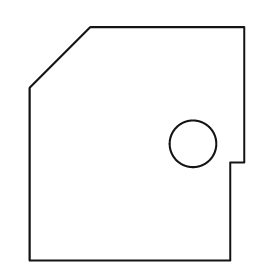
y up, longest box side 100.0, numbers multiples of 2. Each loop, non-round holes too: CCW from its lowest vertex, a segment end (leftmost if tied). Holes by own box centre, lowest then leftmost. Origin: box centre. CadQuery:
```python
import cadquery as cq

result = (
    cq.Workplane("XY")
    .moveTo(-46.0, -50.0)
    .lineTo(40.0, -50.0)
    .lineTo(40.0, -8.0)
    .lineTo(46.0, -8.0)
    .lineTo(46.0, 50.0)
    .lineTo(-20.0, 50.0)
    .lineTo(-46.0, 24.0)
    .close()
    .moveTo(24.0, 0.0)
    .circle(10.0)
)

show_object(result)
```